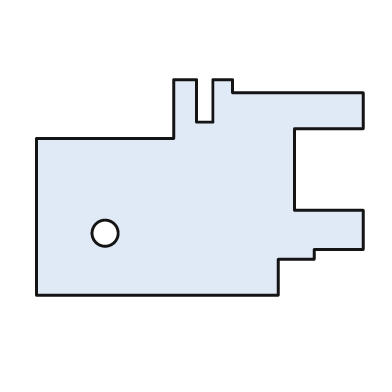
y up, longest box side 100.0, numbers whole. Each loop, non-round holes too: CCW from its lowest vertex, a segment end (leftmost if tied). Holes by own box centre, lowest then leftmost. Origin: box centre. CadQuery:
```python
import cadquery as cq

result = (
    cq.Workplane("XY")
    .moveTo(-50.0, -33.0)
    .lineTo(24.0, -33.0)
    .lineTo(24.0, -22.0)
    .lineTo(35.0, -22.0)
    .lineTo(35.0, -19.0)
    .lineTo(50.0, -19.0)
    .lineTo(50.0, -7.0)
    .lineTo(29.0, -7.0)
    .lineTo(29.0, 18.0)
    .lineTo(50.0, 18.0)
    .lineTo(50.0, 29.0)
    .lineTo(10.0, 29.0)
    .lineTo(10.0, 33.0)
    .lineTo(4.0, 33.0)
    .lineTo(4.0, 20.0)
    .lineTo(-1.0, 20.0)
    .lineTo(-1.0, 33.0)
    .lineTo(-8.0, 33.0)
    .lineTo(-8.0, 15.0)
    .lineTo(-50.0, 15.0)
    .close()
    .moveTo(-29.0, -14.0)
    .circle(4.0)
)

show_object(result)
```